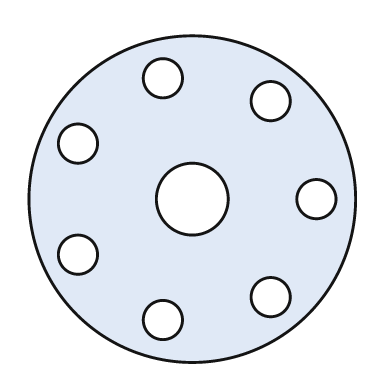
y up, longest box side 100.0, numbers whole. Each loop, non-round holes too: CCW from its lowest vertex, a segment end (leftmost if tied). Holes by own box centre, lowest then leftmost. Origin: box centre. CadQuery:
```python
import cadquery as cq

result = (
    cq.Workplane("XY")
    .moveTo(0.0, 0.0)
    .circle(50.0)
    .moveTo(-9.0, -37.0)
    .circle(6.0)
    .moveTo(24.0, -30.0)
    .circle(6.0)
    .moveTo(-35.0, -17.0)
    .circle(6.0)
    .moveTo(0.0, 0.0)
    .circle(11.0)
    .moveTo(38.0, 0.0)
    .circle(6.0)
    .moveTo(-35.0, 17.0)
    .circle(6.0)
    .moveTo(24.0, 30.0)
    .circle(6.0)
    .moveTo(-9.0, 37.0)
    .circle(6.0)
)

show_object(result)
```